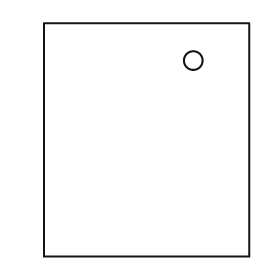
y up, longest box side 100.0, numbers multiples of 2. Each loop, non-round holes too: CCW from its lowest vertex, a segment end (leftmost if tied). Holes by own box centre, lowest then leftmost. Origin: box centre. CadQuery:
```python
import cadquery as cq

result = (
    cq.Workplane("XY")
    .moveTo(-44.0, -50.0)
    .lineTo(44.0, -50.0)
    .lineTo(44.0, 50.0)
    .lineTo(-44.0, 50.0)
    .close()
    .moveTo(20.0, 34.0)
    .circle(4.0)
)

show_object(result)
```